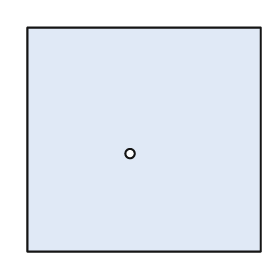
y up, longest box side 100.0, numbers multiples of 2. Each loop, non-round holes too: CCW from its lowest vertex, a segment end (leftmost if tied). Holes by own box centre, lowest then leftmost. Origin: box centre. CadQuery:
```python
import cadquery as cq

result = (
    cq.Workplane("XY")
    .moveTo(-50.0, -48.0)
    .lineTo(50.0, -48.0)
    .lineTo(50.0, 48.0)
    .lineTo(-50.0, 48.0)
    .close()
    .moveTo(-6.0, -6.0)
    .circle(2.0)
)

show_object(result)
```